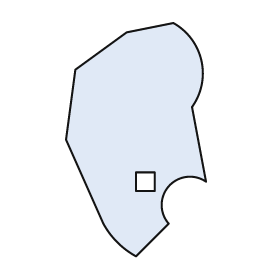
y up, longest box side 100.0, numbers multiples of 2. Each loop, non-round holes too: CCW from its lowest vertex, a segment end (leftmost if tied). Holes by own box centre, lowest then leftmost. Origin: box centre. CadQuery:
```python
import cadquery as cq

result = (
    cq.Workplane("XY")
    .moveTo(0.0, -50.0)
    .lineTo(14.0, -36.0)
    .threePointArc((14.0, -20.0), (30.0, -18.0))
    .lineTo(24.0, 14.0)
    .threePointArc((28.0, 34.0), (16.0, 50.0))
    .lineTo(-4.0, 46.0)
    .lineTo(-26.0, 30.0)
    .lineTo(-30.0, 0.0)
    .lineTo(-14.0, -36.0)
    .threePointArc((-8.0, -44.0), (0.0, -50.0))
    .close()
    .moveTo(0.0, -22.0)
    .lineTo(8.0, -22.0)
    .lineTo(8.0, -14.0)
    .lineTo(0.0, -14.0)
    .close()
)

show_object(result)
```